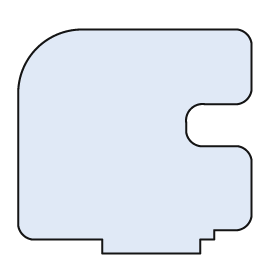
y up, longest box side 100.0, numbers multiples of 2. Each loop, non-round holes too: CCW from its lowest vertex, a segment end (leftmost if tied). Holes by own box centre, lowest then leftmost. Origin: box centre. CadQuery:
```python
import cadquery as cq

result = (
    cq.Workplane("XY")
    .moveTo(-14.0, -48.0)
    .lineTo(28.0, -48.0)
    .lineTo(28.0, -42.0)
    .lineTo(34.0, -42.0)
    .lineTo(34.0, -38.0)
    .lineTo(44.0, -38.0)
    .threePointArc((48.0, -36.0), (50.0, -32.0))
    .lineTo(50.0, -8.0)
    .threePointArc((48.0, -4.0), (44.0, -2.0))
    .lineTo(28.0, -2.0)
    .threePointArc((24.0, 0.0), (22.0, 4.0))
    .lineTo(22.0, 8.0)
    .threePointArc((24.0, 14.0), (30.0, 16.0))
    .lineTo(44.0, 16.0)
    .threePointArc((48.0, 18.0), (50.0, 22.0))
    .lineTo(50.0, 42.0)
    .threePointArc((48.0, 46.0), (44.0, 48.0))
    .lineTo(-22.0, 48.0)
    .threePointArc((-42.0, 40.0), (-50.0, 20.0))
    .lineTo(-50.0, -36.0)
    .threePointArc((-48.0, -40.0), (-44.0, -42.0))
    .lineTo(-14.0, -42.0)
    .close()
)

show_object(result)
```